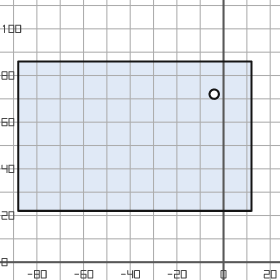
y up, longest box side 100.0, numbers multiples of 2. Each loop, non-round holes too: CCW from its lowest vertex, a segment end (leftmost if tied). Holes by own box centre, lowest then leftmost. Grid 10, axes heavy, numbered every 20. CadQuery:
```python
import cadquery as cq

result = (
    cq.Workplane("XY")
    .moveTo(-88.0, 22.0)
    .lineTo(12.0, 22.0)
    .lineTo(12.0, 86.0)
    .lineTo(-88.0, 86.0)
    .close()
    .moveTo(-4.0, 72.0)
    .circle(2.0)
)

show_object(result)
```